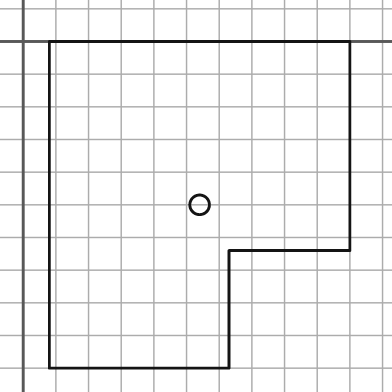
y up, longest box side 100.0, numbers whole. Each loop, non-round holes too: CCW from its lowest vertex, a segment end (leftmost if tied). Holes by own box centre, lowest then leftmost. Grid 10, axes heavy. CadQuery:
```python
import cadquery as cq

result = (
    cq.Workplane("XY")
    .moveTo(8.0, -100.0)
    .lineTo(63.0, -100.0)
    .lineTo(63.0, -64.0)
    .lineTo(100.0, -64.0)
    .lineTo(100.0, 0.0)
    .lineTo(8.0, 0.0)
    .close()
    .moveTo(54.0, -50.0)
    .circle(3.0)
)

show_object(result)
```